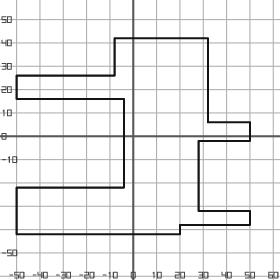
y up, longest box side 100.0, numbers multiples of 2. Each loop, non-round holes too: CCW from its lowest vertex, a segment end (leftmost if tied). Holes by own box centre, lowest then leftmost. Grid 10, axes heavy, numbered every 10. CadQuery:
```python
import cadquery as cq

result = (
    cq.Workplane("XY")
    .moveTo(-50.0, -42.0)
    .lineTo(20.0, -42.0)
    .lineTo(20.0, -38.0)
    .lineTo(50.0, -38.0)
    .lineTo(50.0, -32.0)
    .lineTo(28.0, -32.0)
    .lineTo(28.0, -2.0)
    .lineTo(50.0, -2.0)
    .lineTo(50.0, 6.0)
    .lineTo(32.0, 6.0)
    .lineTo(32.0, 42.0)
    .lineTo(-8.0, 42.0)
    .lineTo(-8.0, 26.0)
    .lineTo(-50.0, 26.0)
    .lineTo(-50.0, 16.0)
    .lineTo(-4.0, 16.0)
    .lineTo(-4.0, -22.0)
    .lineTo(-50.0, -22.0)
    .close()
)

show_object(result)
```